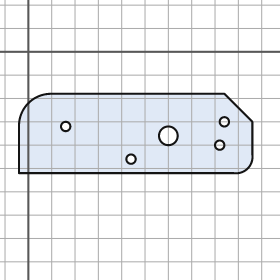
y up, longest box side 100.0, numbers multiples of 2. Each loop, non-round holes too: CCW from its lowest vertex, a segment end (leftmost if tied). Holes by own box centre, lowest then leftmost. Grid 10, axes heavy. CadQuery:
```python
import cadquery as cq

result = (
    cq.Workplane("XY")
    .moveTo(-4.0, -52.0)
    .lineTo(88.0, -52.0)
    .threePointArc((94.0, -50.0), (96.0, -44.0))
    .lineTo(96.0, -30.0)
    .lineTo(84.0, -18.0)
    .lineTo(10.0, -18.0)
    .threePointArc((0.0, -22.0), (-4.0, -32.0))
    .close()
    .moveTo(44.0, -46.0)
    .circle(2.0)
    .moveTo(82.0, -40.0)
    .circle(2.0)
    .moveTo(60.0, -36.0)
    .circle(4.0)
    .moveTo(16.0, -32.0)
    .circle(2.0)
    .moveTo(84.0, -30.0)
    .circle(2.0)
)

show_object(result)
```